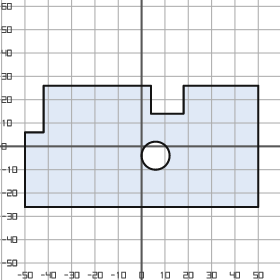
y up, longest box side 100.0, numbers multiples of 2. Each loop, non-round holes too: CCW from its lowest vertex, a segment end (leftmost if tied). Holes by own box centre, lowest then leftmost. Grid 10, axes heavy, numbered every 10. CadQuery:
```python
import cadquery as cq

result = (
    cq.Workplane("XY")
    .moveTo(-50.0, -26.0)
    .lineTo(50.0, -26.0)
    .lineTo(50.0, 26.0)
    .lineTo(18.0, 26.0)
    .lineTo(18.0, 14.0)
    .lineTo(4.0, 14.0)
    .lineTo(4.0, 26.0)
    .lineTo(-42.0, 26.0)
    .lineTo(-42.0, 6.0)
    .lineTo(-50.0, 6.0)
    .close()
    .moveTo(6.0, -4.0)
    .circle(6.0)
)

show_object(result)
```